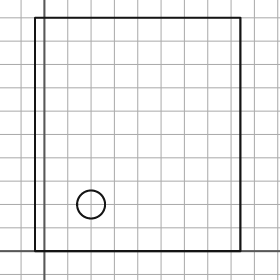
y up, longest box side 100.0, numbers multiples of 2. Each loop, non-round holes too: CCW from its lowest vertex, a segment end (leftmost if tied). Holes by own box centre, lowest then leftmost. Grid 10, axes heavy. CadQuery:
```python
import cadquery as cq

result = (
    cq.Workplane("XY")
    .moveTo(-4.0, 0.0)
    .lineTo(84.0, 0.0)
    .lineTo(84.0, 100.0)
    .lineTo(-4.0, 100.0)
    .close()
    .moveTo(20.0, 20.0)
    .circle(6.0)
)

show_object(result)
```